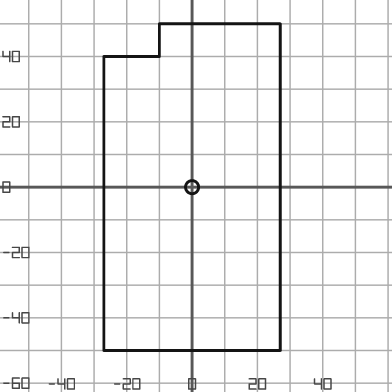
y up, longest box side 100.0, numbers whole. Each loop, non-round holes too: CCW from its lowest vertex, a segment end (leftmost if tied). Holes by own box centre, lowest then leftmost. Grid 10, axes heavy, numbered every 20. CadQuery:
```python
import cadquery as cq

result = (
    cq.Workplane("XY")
    .moveTo(-27.0, -50.0)
    .lineTo(27.0, -50.0)
    .lineTo(27.0, 50.0)
    .lineTo(-10.0, 50.0)
    .lineTo(-10.0, 40.0)
    .lineTo(-27.0, 40.0)
    .close()
    .moveTo(0.0, 0.0)
    .circle(2.0)
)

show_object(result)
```